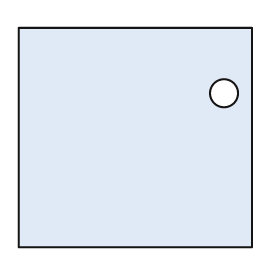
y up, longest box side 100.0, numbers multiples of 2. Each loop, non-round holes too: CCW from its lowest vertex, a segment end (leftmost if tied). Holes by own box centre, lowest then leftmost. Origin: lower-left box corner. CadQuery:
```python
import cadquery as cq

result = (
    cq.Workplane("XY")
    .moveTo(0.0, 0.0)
    .lineTo(100.0, 0.0)
    .lineTo(100.0, 94.0)
    .lineTo(0.0, 94.0)
    .close()
    .moveTo(88.0, 66.0)
    .circle(6.0)
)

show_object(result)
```